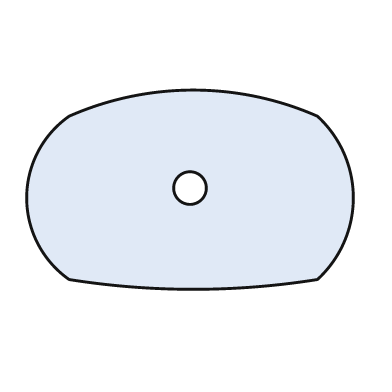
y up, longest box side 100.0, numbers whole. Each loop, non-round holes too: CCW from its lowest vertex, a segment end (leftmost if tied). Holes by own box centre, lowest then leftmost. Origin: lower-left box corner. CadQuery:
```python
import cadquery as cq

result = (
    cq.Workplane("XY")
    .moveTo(13.0, 3.0)
    .threePointArc((51.0, 0.0), (89.0, 3.0))
    .threePointArc((100.0, 28.0), (89.0, 53.0))
    .threePointArc((51.0, 61.0), (13.0, 53.0))
    .threePointArc((0.0, 28.0), (13.0, 3.0))
    .close()
    .moveTo(50.0, 31.0)
    .circle(5.0)
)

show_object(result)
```